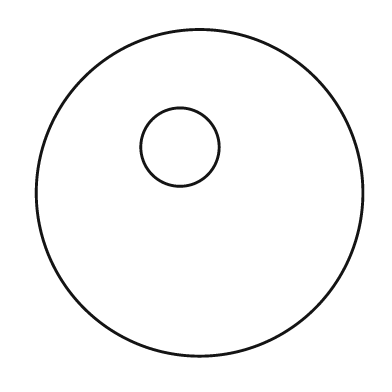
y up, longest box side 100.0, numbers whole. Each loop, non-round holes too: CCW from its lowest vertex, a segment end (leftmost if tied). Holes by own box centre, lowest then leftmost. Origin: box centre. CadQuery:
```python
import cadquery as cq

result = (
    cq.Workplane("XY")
    .moveTo(0.0, 0.0)
    .circle(50.0)
    .moveTo(-6.0, 14.0)
    .circle(12.0)
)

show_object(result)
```